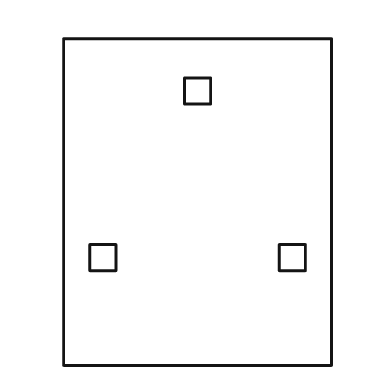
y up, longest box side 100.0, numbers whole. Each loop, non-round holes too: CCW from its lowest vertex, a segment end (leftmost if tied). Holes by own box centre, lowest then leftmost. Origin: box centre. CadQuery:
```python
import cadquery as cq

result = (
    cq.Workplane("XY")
    .moveTo(-41.0, -50.0)
    .lineTo(41.0, -50.0)
    .lineTo(41.0, 50.0)
    .lineTo(-41.0, 50.0)
    .close()
    .moveTo(-33.0, -21.0)
    .lineTo(-25.0, -21.0)
    .lineTo(-25.0, -13.0)
    .lineTo(-33.0, -13.0)
    .close()
    .moveTo(25.0, -21.0)
    .lineTo(33.0, -21.0)
    .lineTo(33.0, -13.0)
    .lineTo(25.0, -13.0)
    .close()
    .moveTo(-4.0, 30.0)
    .lineTo(4.0, 30.0)
    .lineTo(4.0, 38.0)
    .lineTo(-4.0, 38.0)
    .close()
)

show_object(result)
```